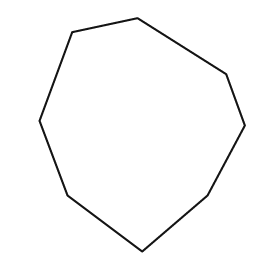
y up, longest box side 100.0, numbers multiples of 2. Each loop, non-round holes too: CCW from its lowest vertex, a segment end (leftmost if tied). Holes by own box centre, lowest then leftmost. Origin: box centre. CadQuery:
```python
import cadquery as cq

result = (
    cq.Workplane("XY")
    .moveTo(0.0, -50.0)
    .lineTo(28.0, -26.0)
    .lineTo(44.0, 4.0)
    .lineTo(36.0, 26.0)
    .lineTo(-2.0, 50.0)
    .lineTo(-30.0, 44.0)
    .lineTo(-44.0, 6.0)
    .lineTo(-32.0, -26.0)
    .close()
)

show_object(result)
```